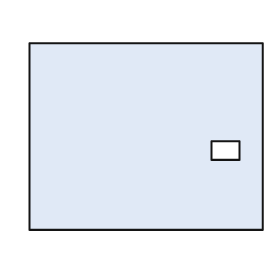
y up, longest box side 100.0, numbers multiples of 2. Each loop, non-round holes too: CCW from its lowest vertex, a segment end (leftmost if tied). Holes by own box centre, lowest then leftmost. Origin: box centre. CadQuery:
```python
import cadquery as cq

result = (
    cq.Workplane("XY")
    .moveTo(-50.0, -40.0)
    .lineTo(50.0, -40.0)
    .lineTo(50.0, 40.0)
    .lineTo(-50.0, 40.0)
    .close()
    .moveTo(28.0, -10.0)
    .lineTo(40.0, -10.0)
    .lineTo(40.0, -2.0)
    .lineTo(28.0, -2.0)
    .close()
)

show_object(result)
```